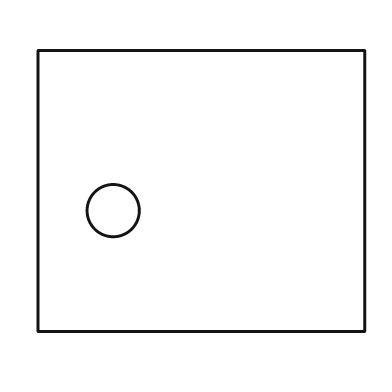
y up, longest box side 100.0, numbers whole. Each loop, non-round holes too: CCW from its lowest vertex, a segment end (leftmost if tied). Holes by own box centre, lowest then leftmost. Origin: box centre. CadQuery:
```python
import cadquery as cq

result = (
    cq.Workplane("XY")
    .moveTo(-50.0, -43.0)
    .lineTo(50.0, -43.0)
    .lineTo(50.0, 43.0)
    .lineTo(-50.0, 43.0)
    .close()
    .moveTo(-27.0, -6.0)
    .circle(8.0)
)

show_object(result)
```